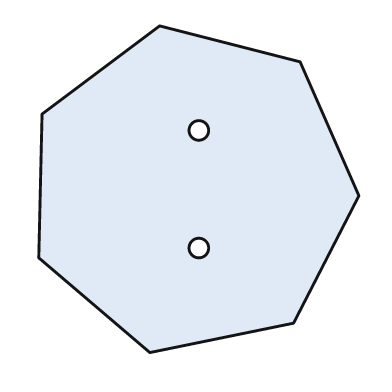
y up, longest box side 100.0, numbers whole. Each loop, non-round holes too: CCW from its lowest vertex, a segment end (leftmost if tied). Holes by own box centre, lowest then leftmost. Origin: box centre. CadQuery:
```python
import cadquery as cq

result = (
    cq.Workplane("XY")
    .moveTo(-15.0, -50.0)
    .lineTo(29.0, -41.0)
    .lineTo(49.0, -2.0)
    .lineTo(31.0, 39.0)
    .lineTo(-12.0, 50.0)
    .lineTo(-48.0, 23.0)
    .lineTo(-49.0, -21.0)
    .close()
    .moveTo(0.0, -18.0)
    .circle(3.0)
    .moveTo(0.0, 18.0)
    .circle(3.0)
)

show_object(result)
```